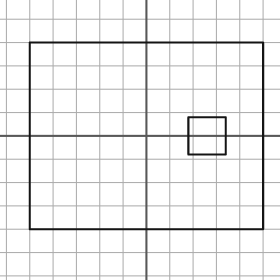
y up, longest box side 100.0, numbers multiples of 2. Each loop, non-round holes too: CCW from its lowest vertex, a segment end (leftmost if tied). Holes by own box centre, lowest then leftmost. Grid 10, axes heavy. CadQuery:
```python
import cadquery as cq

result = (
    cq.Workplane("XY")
    .moveTo(-50.0, -40.0)
    .lineTo(50.0, -40.0)
    .lineTo(50.0, 40.0)
    .lineTo(-50.0, 40.0)
    .close()
    .moveTo(18.0, -8.0)
    .lineTo(34.0, -8.0)
    .lineTo(34.0, 8.0)
    .lineTo(18.0, 8.0)
    .close()
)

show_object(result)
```